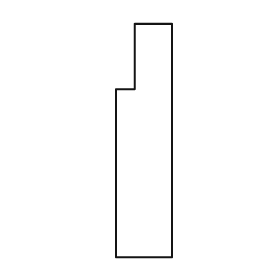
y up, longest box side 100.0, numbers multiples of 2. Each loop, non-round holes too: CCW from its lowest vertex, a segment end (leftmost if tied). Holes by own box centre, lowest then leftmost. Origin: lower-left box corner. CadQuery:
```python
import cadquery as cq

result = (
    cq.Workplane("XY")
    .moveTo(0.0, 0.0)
    .lineTo(24.0, 0.0)
    .lineTo(24.0, 100.0)
    .lineTo(8.0, 100.0)
    .lineTo(8.0, 72.0)
    .lineTo(0.0, 72.0)
    .close()
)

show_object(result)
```